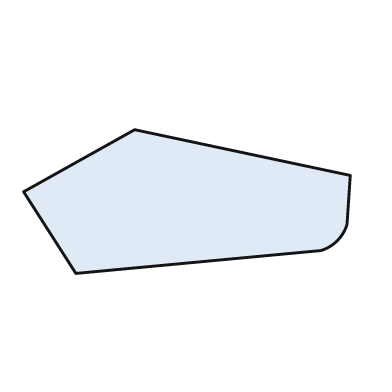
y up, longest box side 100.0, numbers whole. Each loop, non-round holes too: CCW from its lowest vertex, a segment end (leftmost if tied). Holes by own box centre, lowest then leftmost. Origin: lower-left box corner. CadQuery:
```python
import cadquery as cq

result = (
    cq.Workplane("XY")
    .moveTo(16.0, 0.0)
    .lineTo(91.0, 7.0)
    .threePointArc((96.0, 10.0), (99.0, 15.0))
    .lineTo(100.0, 30.0)
    .lineTo(34.0, 44.0)
    .lineTo(0.0, 25.0)
    .close()
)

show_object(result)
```